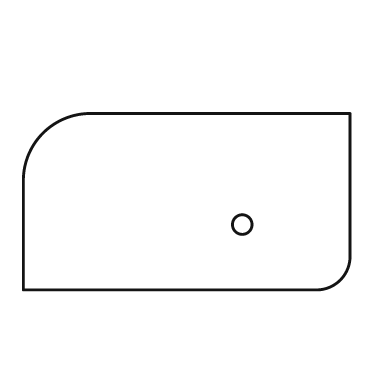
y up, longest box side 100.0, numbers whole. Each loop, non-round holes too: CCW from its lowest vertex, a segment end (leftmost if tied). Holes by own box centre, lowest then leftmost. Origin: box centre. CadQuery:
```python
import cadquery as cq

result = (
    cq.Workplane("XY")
    .moveTo(-50.0, -27.0)
    .lineTo(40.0, -27.0)
    .threePointArc((47.0, -24.0), (50.0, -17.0))
    .lineTo(50.0, 27.0)
    .lineTo(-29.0, 27.0)
    .threePointArc((-44.0, 21.0), (-50.0, 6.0))
    .close()
    .moveTo(17.0, -7.0)
    .circle(3.0)
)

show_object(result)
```